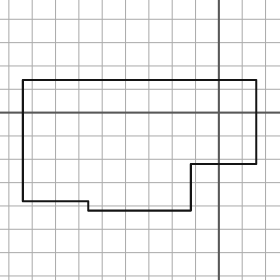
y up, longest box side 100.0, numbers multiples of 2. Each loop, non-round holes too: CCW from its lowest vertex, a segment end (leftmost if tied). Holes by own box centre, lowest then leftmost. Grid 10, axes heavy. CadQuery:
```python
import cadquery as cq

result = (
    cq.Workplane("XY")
    .moveTo(-56.0, -42.0)
    .lineTo(-12.0, -42.0)
    .lineTo(-12.0, -22.0)
    .lineTo(16.0, -22.0)
    .lineTo(16.0, 14.0)
    .lineTo(-84.0, 14.0)
    .lineTo(-84.0, -38.0)
    .lineTo(-56.0, -38.0)
    .close()
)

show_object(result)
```